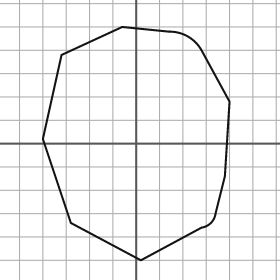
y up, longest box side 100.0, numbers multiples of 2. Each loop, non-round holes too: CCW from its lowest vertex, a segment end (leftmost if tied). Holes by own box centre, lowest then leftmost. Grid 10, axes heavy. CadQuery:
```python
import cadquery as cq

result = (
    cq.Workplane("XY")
    .moveTo(2.0, -50.0)
    .lineTo(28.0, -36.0)
    .threePointArc((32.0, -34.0), (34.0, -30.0))
    .lineTo(38.0, -14.0)
    .lineTo(40.0, 18.0)
    .lineTo(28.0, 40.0)
    .threePointArc((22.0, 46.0), (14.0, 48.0))
    .lineTo(-6.0, 50.0)
    .lineTo(-32.0, 38.0)
    .lineTo(-40.0, 2.0)
    .lineTo(-28.0, -34.0)
    .close()
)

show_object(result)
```